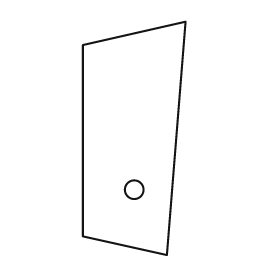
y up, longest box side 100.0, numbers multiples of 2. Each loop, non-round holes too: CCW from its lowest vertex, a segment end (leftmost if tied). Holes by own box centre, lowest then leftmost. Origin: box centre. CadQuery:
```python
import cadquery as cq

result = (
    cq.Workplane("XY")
    .moveTo(14.0, -50.0)
    .lineTo(22.0, 50.0)
    .lineTo(-22.0, 40.0)
    .lineTo(-22.0, -42.0)
    .close()
    .moveTo(0.0, -22.0)
    .circle(4.0)
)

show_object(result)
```